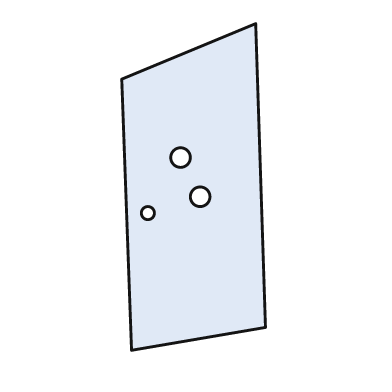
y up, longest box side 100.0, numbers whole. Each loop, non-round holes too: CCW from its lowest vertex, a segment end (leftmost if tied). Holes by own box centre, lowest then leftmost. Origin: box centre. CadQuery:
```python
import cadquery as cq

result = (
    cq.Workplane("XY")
    .moveTo(-19.0, -50.0)
    .lineTo(22.0, -43.0)
    .lineTo(19.0, 50.0)
    .lineTo(-22.0, 33.0)
    .close()
    .moveTo(-14.0, -8.0)
    .circle(2.0)
    .moveTo(2.0, -3.0)
    .circle(3.0)
    .moveTo(-4.0, 9.0)
    .circle(3.0)
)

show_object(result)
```